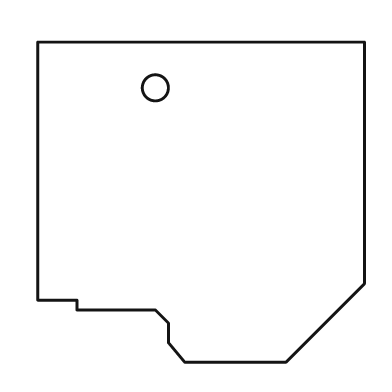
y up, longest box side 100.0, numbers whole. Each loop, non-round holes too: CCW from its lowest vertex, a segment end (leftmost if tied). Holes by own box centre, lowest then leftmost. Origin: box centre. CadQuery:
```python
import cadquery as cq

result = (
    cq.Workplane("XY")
    .moveTo(-5.0, -49.0)
    .lineTo(26.0, -49.0)
    .lineTo(50.0, -25.0)
    .lineTo(50.0, 49.0)
    .lineTo(-50.0, 49.0)
    .lineTo(-50.0, -30.0)
    .lineTo(-38.0, -30.0)
    .lineTo(-38.0, -33.0)
    .lineTo(-14.0, -33.0)
    .lineTo(-10.0, -37.0)
    .lineTo(-10.0, -43.0)
    .close()
    .moveTo(-14.0, 35.0)
    .circle(4.0)
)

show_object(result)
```